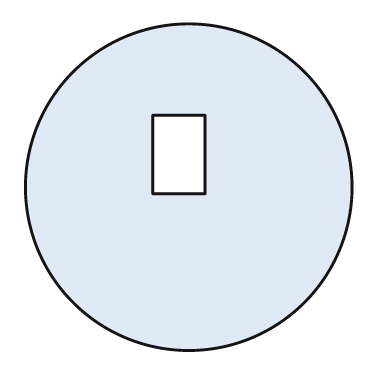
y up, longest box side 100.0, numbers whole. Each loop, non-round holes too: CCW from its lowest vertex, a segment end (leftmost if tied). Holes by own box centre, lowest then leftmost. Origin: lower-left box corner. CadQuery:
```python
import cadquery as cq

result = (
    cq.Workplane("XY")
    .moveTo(50.0, 50.0)
    .circle(50.0)
    .moveTo(39.0, 48.0)
    .lineTo(55.0, 48.0)
    .lineTo(55.0, 72.0)
    .lineTo(39.0, 72.0)
    .close()
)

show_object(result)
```